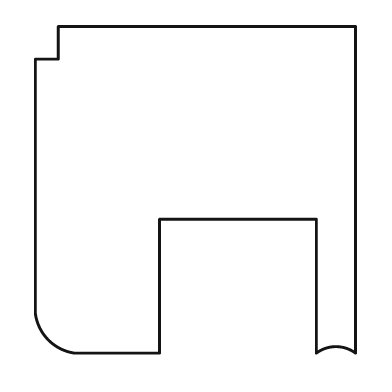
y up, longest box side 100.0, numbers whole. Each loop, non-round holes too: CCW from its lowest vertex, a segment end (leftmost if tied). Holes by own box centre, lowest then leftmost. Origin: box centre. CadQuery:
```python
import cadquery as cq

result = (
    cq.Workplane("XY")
    .moveTo(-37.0, -50.0)
    .lineTo(-11.0, -50.0)
    .lineTo(-11.0, -9.0)
    .lineTo(37.0, -9.0)
    .lineTo(37.0, -50.0)
    .threePointArc((43.0, -48.0), (49.0, -50.0))
    .lineTo(49.0, 50.0)
    .lineTo(-42.0, 50.0)
    .lineTo(-42.0, 40.0)
    .lineTo(-49.0, 40.0)
    .lineTo(-49.0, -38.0)
    .threePointArc((-45.0, -46.0), (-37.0, -50.0))
    .close()
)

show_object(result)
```